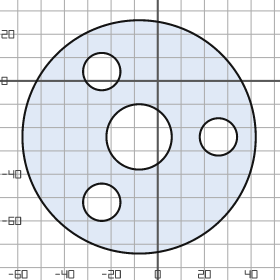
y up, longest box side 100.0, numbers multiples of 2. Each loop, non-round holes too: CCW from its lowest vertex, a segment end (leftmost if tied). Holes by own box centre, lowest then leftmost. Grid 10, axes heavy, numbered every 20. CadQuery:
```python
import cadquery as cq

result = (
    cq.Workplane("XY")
    .moveTo(-8.0, -24.0)
    .circle(50.0)
    .moveTo(-24.0, -52.0)
    .circle(8.0)
    .moveTo(-8.0, -24.0)
    .circle(14.0)
    .moveTo(26.0, -24.0)
    .circle(8.0)
    .moveTo(-24.0, 4.0)
    .circle(8.0)
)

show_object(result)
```